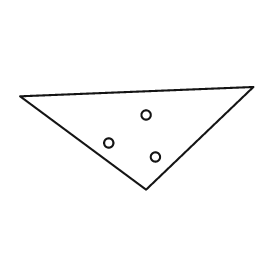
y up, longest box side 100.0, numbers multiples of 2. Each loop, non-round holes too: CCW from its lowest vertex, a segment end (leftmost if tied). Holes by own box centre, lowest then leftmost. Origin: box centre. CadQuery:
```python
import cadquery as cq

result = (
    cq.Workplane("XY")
    .moveTo(4.0, -22.0)
    .lineTo(50.0, 22.0)
    .lineTo(-50.0, 18.0)
    .close()
    .moveTo(8.0, -8.0)
    .circle(2.0)
    .moveTo(-12.0, -2.0)
    .circle(2.0)
    .moveTo(4.0, 10.0)
    .circle(2.0)
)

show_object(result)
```